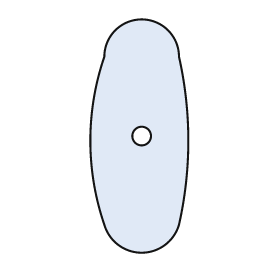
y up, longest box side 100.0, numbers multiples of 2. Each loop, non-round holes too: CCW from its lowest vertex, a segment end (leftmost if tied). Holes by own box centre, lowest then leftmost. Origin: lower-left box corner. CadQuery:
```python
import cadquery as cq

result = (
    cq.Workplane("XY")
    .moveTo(6.0, 12.0)
    .threePointArc((22.0, 0.0), (38.0, 12.0))
    .threePointArc((42.0, 48.0), (38.0, 84.0))
    .threePointArc((22.0, 100.0), (6.0, 84.0))
    .threePointArc((0.0, 48.0), (6.0, 12.0))
    .close()
    .moveTo(22.0, 50.0)
    .circle(4.0)
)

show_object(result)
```